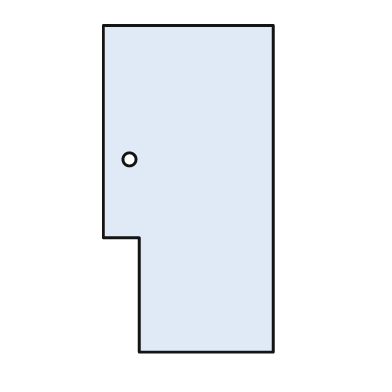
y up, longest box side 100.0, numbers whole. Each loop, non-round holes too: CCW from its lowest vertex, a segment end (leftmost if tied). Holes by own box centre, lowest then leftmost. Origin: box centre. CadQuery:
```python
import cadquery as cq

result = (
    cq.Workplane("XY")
    .moveTo(-15.0, -50.0)
    .lineTo(26.0, -50.0)
    .lineTo(26.0, 50.0)
    .lineTo(-26.0, 50.0)
    .lineTo(-26.0, -15.0)
    .lineTo(-15.0, -15.0)
    .close()
    .moveTo(-18.0, 9.0)
    .circle(2.0)
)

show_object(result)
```